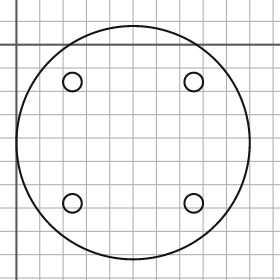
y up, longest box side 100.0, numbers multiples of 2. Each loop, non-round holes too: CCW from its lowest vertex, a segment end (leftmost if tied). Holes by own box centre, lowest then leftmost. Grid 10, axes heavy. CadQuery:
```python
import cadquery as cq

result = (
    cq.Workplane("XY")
    .moveTo(50.0, -42.0)
    .circle(50.0)
    .moveTo(24.0, -68.0)
    .circle(4.0)
    .moveTo(76.0, -68.0)
    .circle(4.0)
    .moveTo(24.0, -16.0)
    .circle(4.0)
    .moveTo(76.0, -16.0)
    .circle(4.0)
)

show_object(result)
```